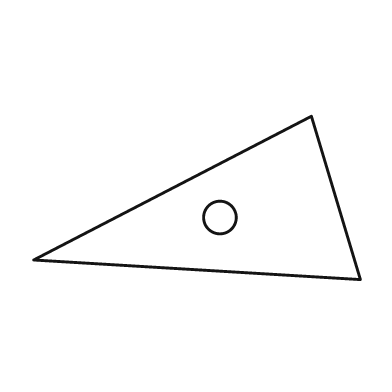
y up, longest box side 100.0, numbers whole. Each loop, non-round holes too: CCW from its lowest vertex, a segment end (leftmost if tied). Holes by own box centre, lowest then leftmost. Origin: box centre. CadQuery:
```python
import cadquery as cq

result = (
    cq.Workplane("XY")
    .moveTo(50.0, -25.0)
    .lineTo(35.0, 25.0)
    .lineTo(-50.0, -19.0)
    .close()
    .moveTo(7.0, -6.0)
    .circle(5.0)
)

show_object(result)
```